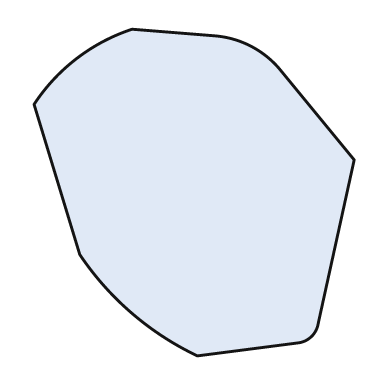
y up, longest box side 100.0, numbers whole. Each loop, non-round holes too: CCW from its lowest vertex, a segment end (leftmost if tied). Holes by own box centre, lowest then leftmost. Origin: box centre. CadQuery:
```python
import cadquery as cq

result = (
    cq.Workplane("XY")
    .moveTo(1.0, -50.0)
    .lineTo(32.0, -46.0)
    .threePointArc((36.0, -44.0), (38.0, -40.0))
    .lineTo(49.0, 10.0)
    .lineTo(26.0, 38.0)
    .threePointArc((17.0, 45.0), (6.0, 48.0))
    .lineTo(-19.0, 50.0)
    .threePointArc((-36.0, 41.0), (-49.0, 27.0))
    .lineTo(-35.0, -19.0)
    .threePointArc((-19.0, -37.0), (1.0, -50.0))
    .close()
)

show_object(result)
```